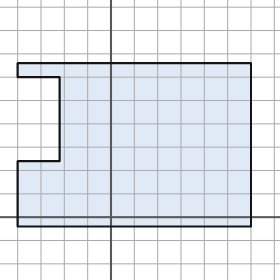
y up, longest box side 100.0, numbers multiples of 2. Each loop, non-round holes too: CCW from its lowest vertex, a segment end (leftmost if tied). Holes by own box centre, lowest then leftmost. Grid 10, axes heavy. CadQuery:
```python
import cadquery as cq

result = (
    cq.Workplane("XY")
    .moveTo(-40.0, -4.0)
    .lineTo(60.0, -4.0)
    .lineTo(60.0, 66.0)
    .lineTo(-40.0, 66.0)
    .lineTo(-40.0, 60.0)
    .lineTo(-22.0, 60.0)
    .lineTo(-22.0, 24.0)
    .lineTo(-40.0, 24.0)
    .close()
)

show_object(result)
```